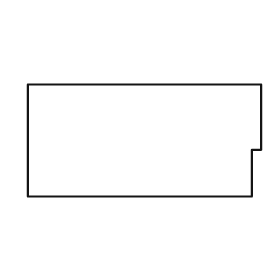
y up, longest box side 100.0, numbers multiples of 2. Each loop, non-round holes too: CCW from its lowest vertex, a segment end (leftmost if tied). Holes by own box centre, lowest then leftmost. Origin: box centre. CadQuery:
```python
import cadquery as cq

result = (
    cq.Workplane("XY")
    .moveTo(-50.0, -24.0)
    .lineTo(46.0, -24.0)
    .lineTo(46.0, -4.0)
    .lineTo(50.0, -4.0)
    .lineTo(50.0, 24.0)
    .lineTo(-50.0, 24.0)
    .close()
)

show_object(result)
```